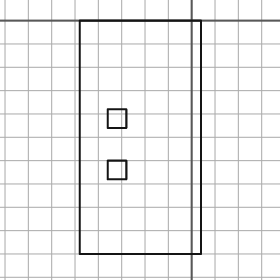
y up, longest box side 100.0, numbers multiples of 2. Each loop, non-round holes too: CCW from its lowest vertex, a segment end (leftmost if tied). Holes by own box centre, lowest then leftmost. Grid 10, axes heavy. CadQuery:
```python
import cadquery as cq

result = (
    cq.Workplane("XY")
    .moveTo(-48.0, -100.0)
    .lineTo(4.0, -100.0)
    .lineTo(4.0, 0.0)
    .lineTo(-48.0, 0.0)
    .close()
    .moveTo(-36.0, -68.0)
    .lineTo(-28.0, -68.0)
    .lineTo(-28.0, -60.0)
    .lineTo(-36.0, -60.0)
    .close()
    .moveTo(-36.0, -46.0)
    .lineTo(-28.0, -46.0)
    .lineTo(-28.0, -38.0)
    .lineTo(-36.0, -38.0)
    .close()
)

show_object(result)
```